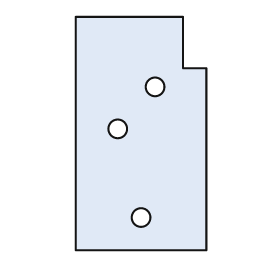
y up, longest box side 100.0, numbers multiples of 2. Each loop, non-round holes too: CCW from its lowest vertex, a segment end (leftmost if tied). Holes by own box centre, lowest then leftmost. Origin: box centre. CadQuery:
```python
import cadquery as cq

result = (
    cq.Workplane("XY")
    .moveTo(-28.0, -50.0)
    .lineTo(28.0, -50.0)
    .lineTo(28.0, 28.0)
    .lineTo(18.0, 28.0)
    .lineTo(18.0, 50.0)
    .lineTo(-28.0, 50.0)
    .close()
    .moveTo(0.0, -36.0)
    .circle(4.0)
    .moveTo(-10.0, 2.0)
    .circle(4.0)
    .moveTo(6.0, 20.0)
    .circle(4.0)
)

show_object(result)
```